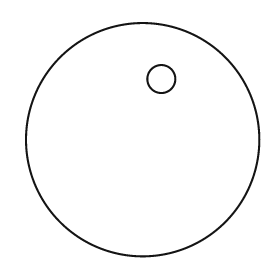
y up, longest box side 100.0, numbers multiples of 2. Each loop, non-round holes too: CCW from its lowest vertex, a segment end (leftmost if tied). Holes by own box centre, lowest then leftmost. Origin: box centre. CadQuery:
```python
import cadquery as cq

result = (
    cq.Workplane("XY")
    .moveTo(0.0, 0.0)
    .circle(50.0)
    .moveTo(8.0, 26.0)
    .circle(6.0)
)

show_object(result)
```